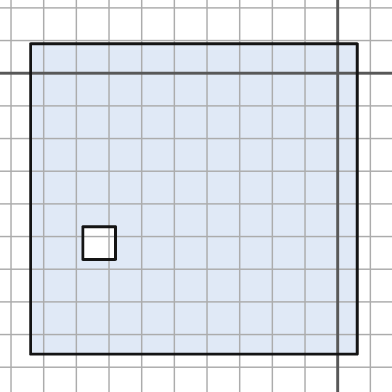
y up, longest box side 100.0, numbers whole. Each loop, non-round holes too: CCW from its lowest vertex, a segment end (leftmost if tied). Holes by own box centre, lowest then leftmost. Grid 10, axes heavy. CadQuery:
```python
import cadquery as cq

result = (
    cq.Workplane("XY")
    .moveTo(-94.0, -86.0)
    .lineTo(6.0, -86.0)
    .lineTo(6.0, 9.0)
    .lineTo(-94.0, 9.0)
    .close()
    .moveTo(-78.0, -57.0)
    .lineTo(-68.0, -57.0)
    .lineTo(-68.0, -47.0)
    .lineTo(-78.0, -47.0)
    .close()
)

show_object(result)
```